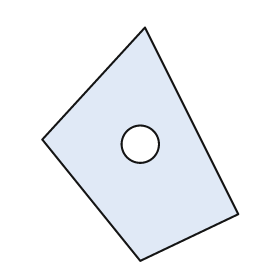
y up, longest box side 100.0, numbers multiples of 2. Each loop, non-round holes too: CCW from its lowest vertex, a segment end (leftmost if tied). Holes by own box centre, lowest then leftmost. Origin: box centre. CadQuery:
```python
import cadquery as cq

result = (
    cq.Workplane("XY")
    .moveTo(0.0, -50.0)
    .lineTo(42.0, -30.0)
    .lineTo(2.0, 50.0)
    .lineTo(-42.0, 2.0)
    .close()
    .moveTo(0.0, 0.0)
    .circle(8.0)
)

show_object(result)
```